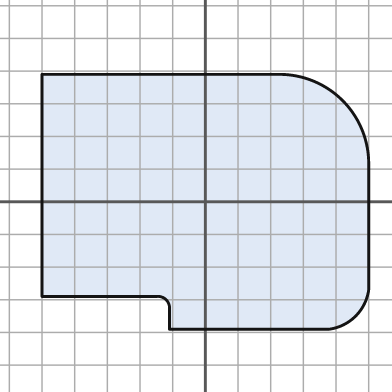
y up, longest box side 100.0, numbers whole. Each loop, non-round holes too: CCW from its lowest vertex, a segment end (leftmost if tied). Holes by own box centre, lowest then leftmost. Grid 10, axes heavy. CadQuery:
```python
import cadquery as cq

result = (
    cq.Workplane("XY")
    .moveTo(-11.0, -39.0)
    .lineTo(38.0, -39.0)
    .threePointArc((46.0, -35.0), (50.0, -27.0))
    .lineTo(50.0, 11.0)
    .threePointArc((42.0, 31.0), (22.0, 39.0))
    .lineTo(-50.0, 39.0)
    .lineTo(-50.0, -29.0)
    .lineTo(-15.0, -29.0)
    .threePointArc((-12.0, -30.0), (-11.0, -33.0))
    .close()
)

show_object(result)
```